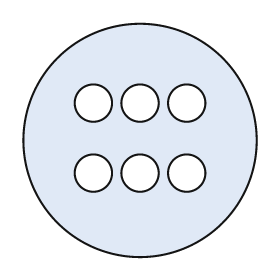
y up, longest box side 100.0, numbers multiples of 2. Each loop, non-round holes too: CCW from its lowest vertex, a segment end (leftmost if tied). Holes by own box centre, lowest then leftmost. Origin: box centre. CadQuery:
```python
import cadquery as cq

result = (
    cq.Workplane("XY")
    .moveTo(0.0, 0.0)
    .circle(50.0)
    .moveTo(-20.0, -14.0)
    .circle(8.0)
    .moveTo(0.0, -14.0)
    .circle(8.0)
    .moveTo(20.0, -14.0)
    .circle(8.0)
    .moveTo(-20.0, 16.0)
    .circle(8.0)
    .moveTo(0.0, 16.0)
    .circle(8.0)
    .moveTo(20.0, 16.0)
    .circle(8.0)
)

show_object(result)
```